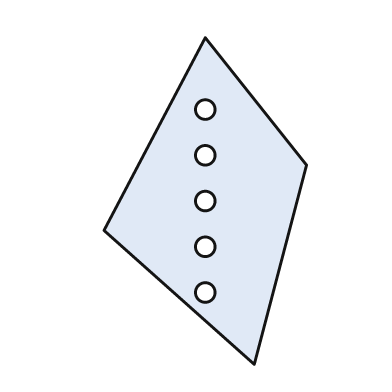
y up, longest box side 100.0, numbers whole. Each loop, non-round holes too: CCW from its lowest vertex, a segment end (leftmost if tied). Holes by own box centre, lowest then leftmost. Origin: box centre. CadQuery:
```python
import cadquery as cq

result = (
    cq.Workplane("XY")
    .moveTo(15.0, -50.0)
    .lineTo(31.0, 11.0)
    .lineTo(0.0, 50.0)
    .lineTo(-31.0, -9.0)
    .close()
    .moveTo(0.0, -28.0)
    .circle(3.0)
    .moveTo(0.0, -14.0)
    .circle(3.0)
    .moveTo(0.0, 0.0)
    .circle(3.0)
    .moveTo(0.0, 14.0)
    .circle(3.0)
    .moveTo(0.0, 28.0)
    .circle(3.0)
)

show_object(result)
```